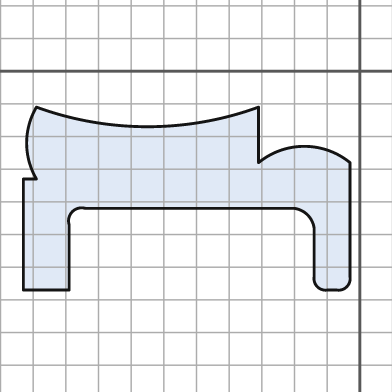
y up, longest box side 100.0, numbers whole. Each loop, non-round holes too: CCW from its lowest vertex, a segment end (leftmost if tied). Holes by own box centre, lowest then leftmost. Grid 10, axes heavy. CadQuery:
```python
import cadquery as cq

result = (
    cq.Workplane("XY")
    .moveTo(-103.0, -67.0)
    .lineTo(-89.0, -67.0)
    .lineTo(-89.0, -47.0)
    .threePointArc((-88.0, -43.0), (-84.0, -42.0))
    .lineTo(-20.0, -42.0)
    .threePointArc((-16.0, -44.0), (-14.0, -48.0))
    .lineTo(-14.0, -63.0)
    .threePointArc((-13.0, -66.0), (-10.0, -67.0))
    .lineTo(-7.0, -67.0)
    .threePointArc((-4.0, -66.0), (-3.0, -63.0))
    .lineTo(-3.0, -28.0)
    .threePointArc((-17.0, -23.0), (-31.0, -28.0))
    .lineTo(-31.0, -11.0)
    .threePointArc((-65.0, -17.0), (-99.0, -11.0))
    .threePointArc((-102.0, -22.0), (-99.0, -33.0))
    .lineTo(-103.0, -33.0)
    .close()
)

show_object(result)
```